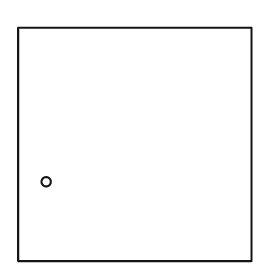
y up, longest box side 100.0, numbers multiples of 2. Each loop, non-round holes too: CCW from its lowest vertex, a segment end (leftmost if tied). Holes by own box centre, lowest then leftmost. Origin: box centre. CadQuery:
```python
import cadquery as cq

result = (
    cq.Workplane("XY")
    .moveTo(-50.0, -50.0)
    .lineTo(50.0, -50.0)
    .lineTo(50.0, 50.0)
    .lineTo(-50.0, 50.0)
    .close()
    .moveTo(-38.0, -16.0)
    .circle(2.0)
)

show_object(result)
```